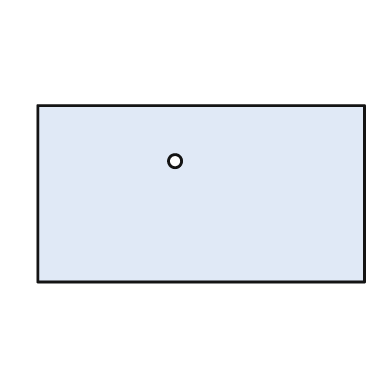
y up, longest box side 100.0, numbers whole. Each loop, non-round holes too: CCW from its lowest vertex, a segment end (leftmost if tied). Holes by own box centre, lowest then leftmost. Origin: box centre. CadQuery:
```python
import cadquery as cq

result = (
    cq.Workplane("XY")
    .moveTo(-50.0, -27.0)
    .lineTo(50.0, -27.0)
    .lineTo(50.0, 27.0)
    .lineTo(-50.0, 27.0)
    .close()
    .moveTo(-8.0, 10.0)
    .circle(2.0)
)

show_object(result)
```